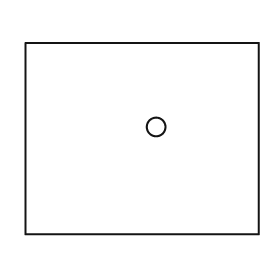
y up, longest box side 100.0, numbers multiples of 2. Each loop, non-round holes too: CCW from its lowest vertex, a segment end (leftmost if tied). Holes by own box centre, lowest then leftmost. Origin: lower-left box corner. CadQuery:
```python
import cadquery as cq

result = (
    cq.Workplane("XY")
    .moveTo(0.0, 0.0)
    .lineTo(100.0, 0.0)
    .lineTo(100.0, 82.0)
    .lineTo(0.0, 82.0)
    .close()
    .moveTo(56.0, 46.0)
    .circle(4.0)
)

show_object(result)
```